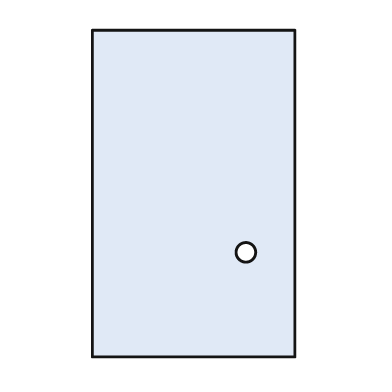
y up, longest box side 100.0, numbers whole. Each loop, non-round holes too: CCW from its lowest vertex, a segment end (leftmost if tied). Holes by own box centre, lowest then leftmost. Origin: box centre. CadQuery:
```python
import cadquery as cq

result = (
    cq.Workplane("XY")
    .moveTo(-31.0, -50.0)
    .lineTo(31.0, -50.0)
    .lineTo(31.0, 50.0)
    .lineTo(-31.0, 50.0)
    .close()
    .moveTo(16.0, -18.0)
    .circle(3.0)
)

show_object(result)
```